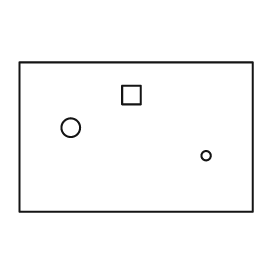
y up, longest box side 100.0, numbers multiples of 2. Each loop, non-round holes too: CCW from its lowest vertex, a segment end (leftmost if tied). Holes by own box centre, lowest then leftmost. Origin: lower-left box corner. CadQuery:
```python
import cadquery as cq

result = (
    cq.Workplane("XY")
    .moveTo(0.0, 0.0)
    .lineTo(100.0, 0.0)
    .lineTo(100.0, 64.0)
    .lineTo(0.0, 64.0)
    .close()
    .moveTo(80.0, 24.0)
    .circle(2.0)
    .moveTo(22.0, 36.0)
    .circle(4.0)
    .moveTo(44.0, 46.0)
    .lineTo(52.0, 46.0)
    .lineTo(52.0, 54.0)
    .lineTo(44.0, 54.0)
    .close()
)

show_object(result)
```